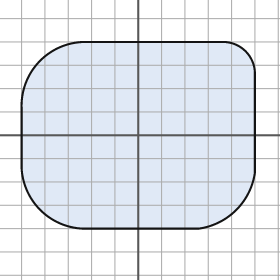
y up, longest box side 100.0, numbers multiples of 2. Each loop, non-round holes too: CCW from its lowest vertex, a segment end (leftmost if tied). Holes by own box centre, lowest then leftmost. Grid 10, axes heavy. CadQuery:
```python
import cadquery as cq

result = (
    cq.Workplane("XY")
    .moveTo(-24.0, -40.0)
    .lineTo(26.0, -40.0)
    .threePointArc((42.0, -32.0), (50.0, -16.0))
    .lineTo(50.0, 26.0)
    .threePointArc((46.0, 36.0), (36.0, 40.0))
    .lineTo(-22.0, 40.0)
    .threePointArc((-42.0, 32.0), (-50.0, 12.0))
    .lineTo(-50.0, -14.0)
    .threePointArc((-42.0, -32.0), (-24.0, -40.0))
    .close()
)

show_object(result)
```